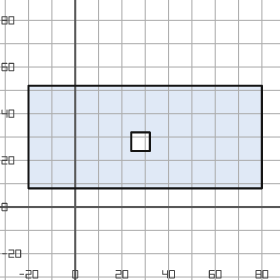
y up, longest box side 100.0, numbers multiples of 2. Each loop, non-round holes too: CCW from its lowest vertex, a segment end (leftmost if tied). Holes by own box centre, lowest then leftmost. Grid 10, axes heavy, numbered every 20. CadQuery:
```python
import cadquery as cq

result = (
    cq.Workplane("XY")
    .moveTo(-20.0, 8.0)
    .lineTo(80.0, 8.0)
    .lineTo(80.0, 52.0)
    .lineTo(-20.0, 52.0)
    .close()
    .moveTo(24.0, 24.0)
    .lineTo(32.0, 24.0)
    .lineTo(32.0, 32.0)
    .lineTo(24.0, 32.0)
    .close()
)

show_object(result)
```